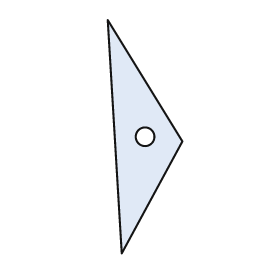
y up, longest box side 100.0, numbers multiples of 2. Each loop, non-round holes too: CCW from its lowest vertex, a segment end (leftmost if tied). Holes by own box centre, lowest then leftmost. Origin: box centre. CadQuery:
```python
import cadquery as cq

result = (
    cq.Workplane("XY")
    .moveTo(-10.0, -50.0)
    .lineTo(16.0, -2.0)
    .lineTo(-16.0, 50.0)
    .close()
    .moveTo(0.0, 0.0)
    .circle(4.0)
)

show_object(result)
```